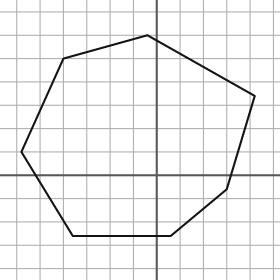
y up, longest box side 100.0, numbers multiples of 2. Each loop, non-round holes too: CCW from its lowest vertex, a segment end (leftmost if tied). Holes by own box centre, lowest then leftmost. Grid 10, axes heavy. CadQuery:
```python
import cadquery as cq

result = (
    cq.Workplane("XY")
    .moveTo(-36.0, -26.0)
    .lineTo(6.0, -26.0)
    .lineTo(30.0, -6.0)
    .lineTo(42.0, 34.0)
    .lineTo(-4.0, 60.0)
    .lineTo(-40.0, 50.0)
    .lineTo(-58.0, 10.0)
    .close()
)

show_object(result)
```